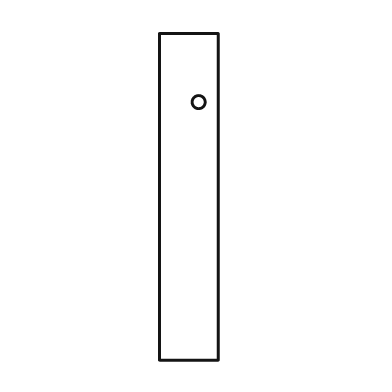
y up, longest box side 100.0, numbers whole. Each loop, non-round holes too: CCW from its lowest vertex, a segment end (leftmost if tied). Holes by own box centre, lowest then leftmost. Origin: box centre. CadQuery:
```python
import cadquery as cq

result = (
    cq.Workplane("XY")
    .moveTo(-9.0, -50.0)
    .lineTo(9.0, -50.0)
    .lineTo(9.0, 50.0)
    .lineTo(-9.0, 50.0)
    .close()
    .moveTo(3.0, 29.0)
    .circle(2.0)
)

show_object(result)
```